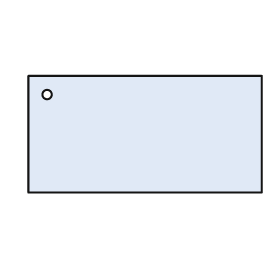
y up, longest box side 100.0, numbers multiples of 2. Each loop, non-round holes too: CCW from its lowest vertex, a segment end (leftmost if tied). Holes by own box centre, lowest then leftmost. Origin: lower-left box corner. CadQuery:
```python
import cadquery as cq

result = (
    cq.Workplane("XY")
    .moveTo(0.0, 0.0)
    .lineTo(100.0, 0.0)
    .lineTo(100.0, 50.0)
    .lineTo(0.0, 50.0)
    .close()
    .moveTo(8.0, 42.0)
    .circle(2.0)
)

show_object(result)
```